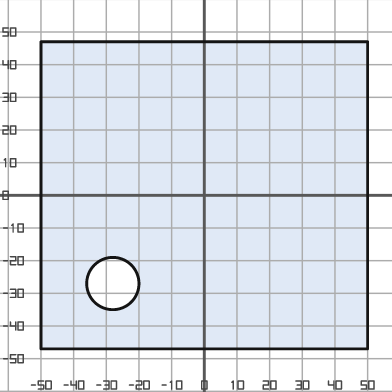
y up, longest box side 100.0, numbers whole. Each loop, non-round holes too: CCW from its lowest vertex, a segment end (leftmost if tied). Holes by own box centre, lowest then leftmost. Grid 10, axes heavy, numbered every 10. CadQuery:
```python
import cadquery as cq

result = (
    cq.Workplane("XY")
    .moveTo(-50.0, -47.0)
    .lineTo(50.0, -47.0)
    .lineTo(50.0, 47.0)
    .lineTo(-50.0, 47.0)
    .close()
    .moveTo(-28.0, -27.0)
    .circle(8.0)
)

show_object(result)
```